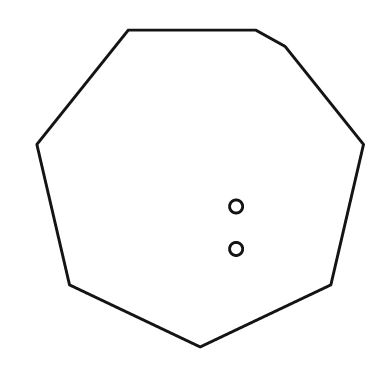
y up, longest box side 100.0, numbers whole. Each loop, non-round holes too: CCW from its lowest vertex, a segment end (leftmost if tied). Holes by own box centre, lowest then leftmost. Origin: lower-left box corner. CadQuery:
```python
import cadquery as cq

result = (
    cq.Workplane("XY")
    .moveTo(50.0, 0.0)
    .lineTo(90.0, 19.0)
    .lineTo(100.0, 62.0)
    .lineTo(76.0, 92.0)
    .lineTo(67.0, 97.0)
    .lineTo(28.0, 97.0)
    .lineTo(0.0, 62.0)
    .lineTo(10.0, 19.0)
    .close()
    .moveTo(61.0, 30.0)
    .circle(2.0)
    .moveTo(61.0, 43.0)
    .circle(2.0)
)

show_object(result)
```